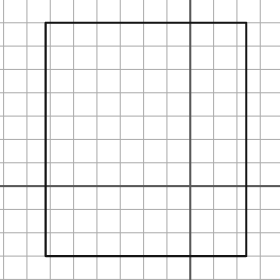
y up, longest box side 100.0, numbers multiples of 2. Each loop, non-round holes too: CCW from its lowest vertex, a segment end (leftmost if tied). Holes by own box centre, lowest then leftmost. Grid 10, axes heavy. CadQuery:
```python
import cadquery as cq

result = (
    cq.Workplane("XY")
    .moveTo(-62.0, -30.0)
    .lineTo(24.0, -30.0)
    .lineTo(24.0, 70.0)
    .lineTo(-62.0, 70.0)
    .close()
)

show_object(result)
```